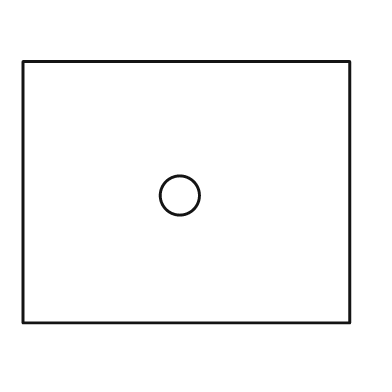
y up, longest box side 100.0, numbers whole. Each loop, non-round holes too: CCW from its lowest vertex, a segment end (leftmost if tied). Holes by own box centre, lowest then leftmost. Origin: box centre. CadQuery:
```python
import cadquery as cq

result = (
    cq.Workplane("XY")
    .moveTo(-50.0, -40.0)
    .lineTo(50.0, -40.0)
    .lineTo(50.0, 40.0)
    .lineTo(-50.0, 40.0)
    .close()
    .moveTo(-2.0, -1.0)
    .circle(6.0)
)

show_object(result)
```